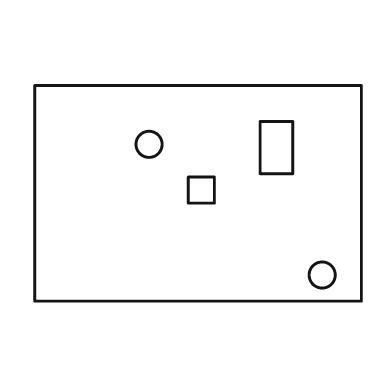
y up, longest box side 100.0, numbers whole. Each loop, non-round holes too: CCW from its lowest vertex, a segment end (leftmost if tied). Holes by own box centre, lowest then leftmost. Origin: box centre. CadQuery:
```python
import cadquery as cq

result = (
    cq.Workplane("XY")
    .moveTo(-50.0, -33.0)
    .lineTo(50.0, -33.0)
    .lineTo(50.0, 33.0)
    .lineTo(-50.0, 33.0)
    .close()
    .moveTo(38.0, -25.0)
    .circle(4.0)
    .moveTo(-3.0, -3.0)
    .lineTo(5.0, -3.0)
    .lineTo(5.0, 5.0)
    .lineTo(-3.0, 5.0)
    .close()
    .moveTo(19.0, 6.0)
    .lineTo(29.0, 6.0)
    .lineTo(29.0, 22.0)
    .lineTo(19.0, 22.0)
    .close()
    .moveTo(-15.0, 15.0)
    .circle(4.0)
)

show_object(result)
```